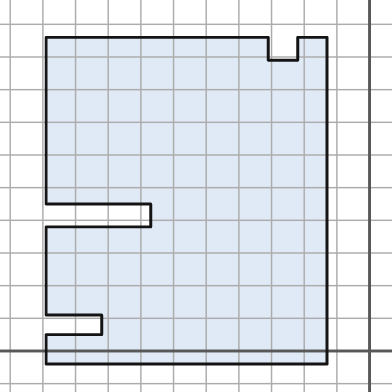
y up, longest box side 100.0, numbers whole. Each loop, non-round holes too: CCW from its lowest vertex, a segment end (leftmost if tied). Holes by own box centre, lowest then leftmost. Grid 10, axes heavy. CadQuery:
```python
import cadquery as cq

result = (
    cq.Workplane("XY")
    .moveTo(-99.0, -4.0)
    .lineTo(-13.0, -4.0)
    .lineTo(-13.0, 96.0)
    .lineTo(-22.0, 96.0)
    .lineTo(-22.0, 89.0)
    .lineTo(-31.0, 89.0)
    .lineTo(-31.0, 96.0)
    .lineTo(-99.0, 96.0)
    .lineTo(-99.0, 45.0)
    .lineTo(-67.0, 45.0)
    .lineTo(-67.0, 38.0)
    .lineTo(-99.0, 38.0)
    .lineTo(-99.0, 11.0)
    .lineTo(-82.0, 11.0)
    .lineTo(-82.0, 5.0)
    .lineTo(-99.0, 5.0)
    .close()
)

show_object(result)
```